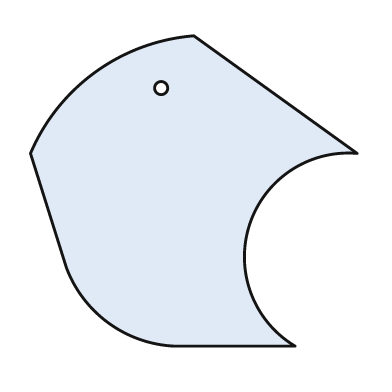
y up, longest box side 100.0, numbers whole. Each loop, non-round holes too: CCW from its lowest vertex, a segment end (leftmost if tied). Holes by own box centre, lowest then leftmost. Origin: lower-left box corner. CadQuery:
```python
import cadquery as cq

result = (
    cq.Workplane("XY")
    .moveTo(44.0, 0.0)
    .lineTo(81.0, 0.0)
    .threePointArc((67.0, 37.0), (100.0, 59.0))
    .lineTo(50.0, 95.0)
    .threePointArc((20.0, 84.0), (0.0, 59.0))
    .lineTo(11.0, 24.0)
    .threePointArc((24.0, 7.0), (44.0, 0.0))
    .close()
    .moveTo(40.0, 79.0)
    .circle(2.0)
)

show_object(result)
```